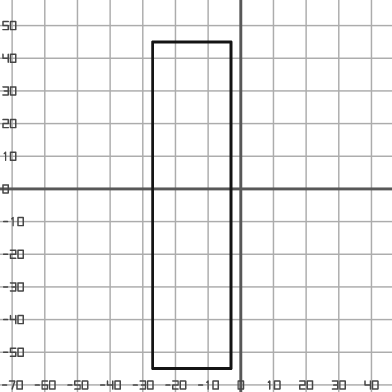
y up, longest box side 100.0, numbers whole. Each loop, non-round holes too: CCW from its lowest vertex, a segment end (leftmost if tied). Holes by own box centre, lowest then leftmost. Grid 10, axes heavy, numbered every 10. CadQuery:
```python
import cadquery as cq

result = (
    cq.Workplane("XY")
    .moveTo(-27.0, -55.0)
    .lineTo(-3.0, -55.0)
    .lineTo(-3.0, 45.0)
    .lineTo(-27.0, 45.0)
    .close()
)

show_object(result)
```